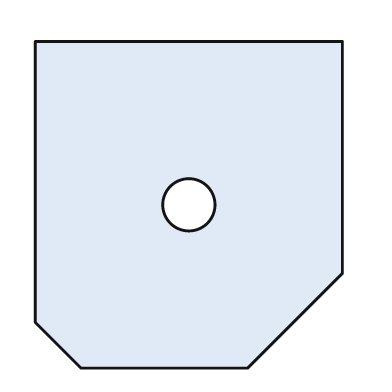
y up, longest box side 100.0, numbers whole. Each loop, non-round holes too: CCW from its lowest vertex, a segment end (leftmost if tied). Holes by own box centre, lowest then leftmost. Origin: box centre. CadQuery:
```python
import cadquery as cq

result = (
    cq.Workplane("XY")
    .moveTo(-33.0, -50.0)
    .lineTo(18.0, -50.0)
    .lineTo(47.0, -21.0)
    .lineTo(47.0, 50.0)
    .lineTo(-47.0, 50.0)
    .lineTo(-47.0, -36.0)
    .close()
    .moveTo(0.0, 0.0)
    .circle(8.0)
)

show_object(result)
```